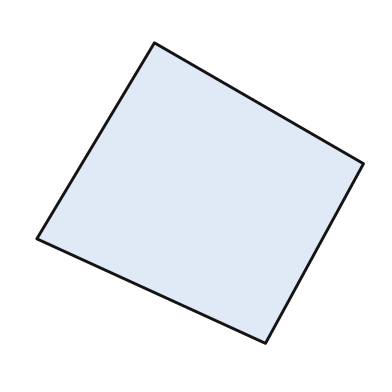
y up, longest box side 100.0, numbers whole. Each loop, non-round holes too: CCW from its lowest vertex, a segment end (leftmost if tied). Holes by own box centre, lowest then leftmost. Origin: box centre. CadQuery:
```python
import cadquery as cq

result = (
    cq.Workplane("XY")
    .moveTo(20.0, -46.0)
    .lineTo(50.0, 9.0)
    .lineTo(-14.0, 46.0)
    .lineTo(-50.0, -14.0)
    .close()
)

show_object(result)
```